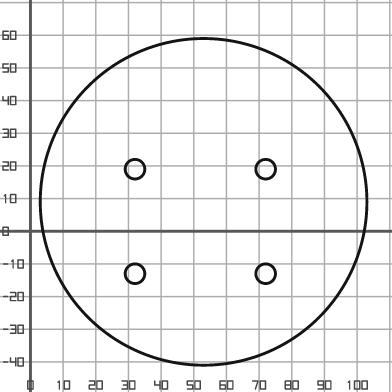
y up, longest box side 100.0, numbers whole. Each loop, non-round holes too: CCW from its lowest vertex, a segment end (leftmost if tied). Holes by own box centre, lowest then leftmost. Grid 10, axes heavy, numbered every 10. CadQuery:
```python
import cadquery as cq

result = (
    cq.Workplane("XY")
    .moveTo(53.0, 9.0)
    .circle(50.0)
    .moveTo(32.0, -13.0)
    .circle(3.0)
    .moveTo(72.0, -13.0)
    .circle(3.0)
    .moveTo(32.0, 19.0)
    .circle(3.0)
    .moveTo(72.0, 19.0)
    .circle(3.0)
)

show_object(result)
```